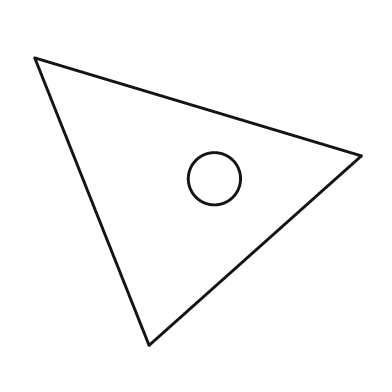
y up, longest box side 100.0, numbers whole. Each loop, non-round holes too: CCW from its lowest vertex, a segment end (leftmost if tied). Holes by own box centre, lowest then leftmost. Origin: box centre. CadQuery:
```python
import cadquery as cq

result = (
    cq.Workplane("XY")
    .moveTo(-15.0, -44.0)
    .lineTo(50.0, 14.0)
    .lineTo(-50.0, 44.0)
    .close()
    .moveTo(5.0, 7.0)
    .circle(8.0)
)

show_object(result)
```